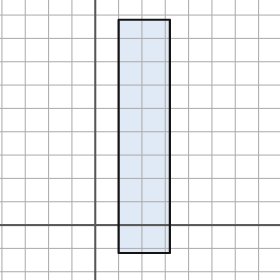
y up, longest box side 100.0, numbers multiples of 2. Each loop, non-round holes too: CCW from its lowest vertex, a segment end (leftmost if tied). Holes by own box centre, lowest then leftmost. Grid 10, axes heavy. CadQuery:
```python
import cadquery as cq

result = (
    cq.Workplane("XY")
    .moveTo(10.0, -12.0)
    .lineTo(32.0, -12.0)
    .lineTo(32.0, 88.0)
    .lineTo(10.0, 88.0)
    .close()
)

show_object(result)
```